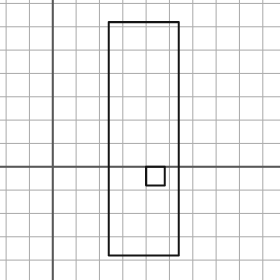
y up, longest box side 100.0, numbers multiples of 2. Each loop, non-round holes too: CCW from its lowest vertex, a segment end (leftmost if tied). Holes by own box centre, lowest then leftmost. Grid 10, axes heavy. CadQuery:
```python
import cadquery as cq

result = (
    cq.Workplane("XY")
    .moveTo(24.0, -38.0)
    .lineTo(54.0, -38.0)
    .lineTo(54.0, 62.0)
    .lineTo(24.0, 62.0)
    .close()
    .moveTo(40.0, -8.0)
    .lineTo(48.0, -8.0)
    .lineTo(48.0, 0.0)
    .lineTo(40.0, 0.0)
    .close()
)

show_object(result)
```